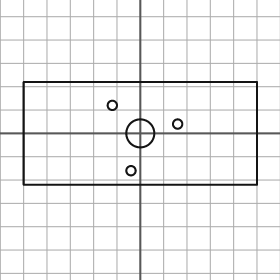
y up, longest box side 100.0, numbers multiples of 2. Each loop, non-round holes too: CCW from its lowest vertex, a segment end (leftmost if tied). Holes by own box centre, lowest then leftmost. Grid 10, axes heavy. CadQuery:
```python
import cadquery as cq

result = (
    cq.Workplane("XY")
    .moveTo(-50.0, -22.0)
    .lineTo(50.0, -22.0)
    .lineTo(50.0, 22.0)
    .lineTo(-50.0, 22.0)
    .close()
    .moveTo(-4.0, -16.0)
    .circle(2.0)
    .moveTo(0.0, 0.0)
    .circle(6.0)
    .moveTo(16.0, 4.0)
    .circle(2.0)
    .moveTo(-12.0, 12.0)
    .circle(2.0)
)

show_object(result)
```